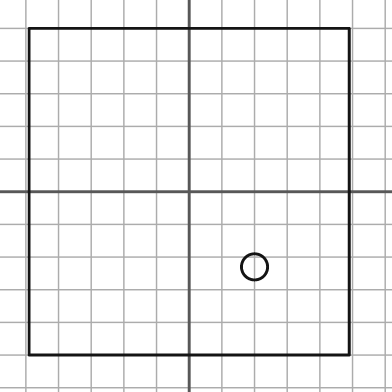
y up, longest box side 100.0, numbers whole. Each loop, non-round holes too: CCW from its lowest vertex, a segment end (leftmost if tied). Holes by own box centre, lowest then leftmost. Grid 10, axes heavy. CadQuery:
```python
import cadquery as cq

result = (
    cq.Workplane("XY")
    .moveTo(-49.0, -50.0)
    .lineTo(49.0, -50.0)
    .lineTo(49.0, 50.0)
    .lineTo(-49.0, 50.0)
    .close()
    .moveTo(20.0, -23.0)
    .circle(4.0)
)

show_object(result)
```